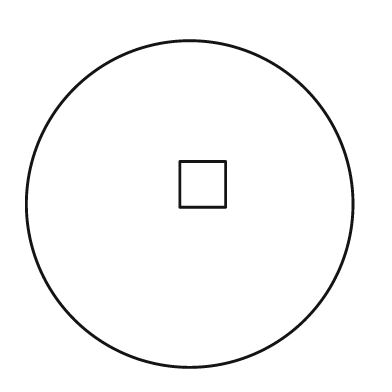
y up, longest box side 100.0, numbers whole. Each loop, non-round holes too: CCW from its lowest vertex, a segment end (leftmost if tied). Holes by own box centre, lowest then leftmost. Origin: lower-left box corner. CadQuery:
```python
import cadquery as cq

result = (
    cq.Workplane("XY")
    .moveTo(50.0, 50.0)
    .circle(50.0)
    .moveTo(47.0, 49.0)
    .lineTo(61.0, 49.0)
    .lineTo(61.0, 63.0)
    .lineTo(47.0, 63.0)
    .close()
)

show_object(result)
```